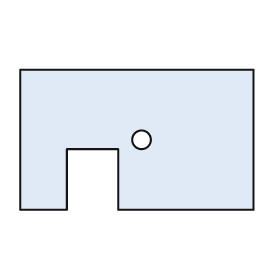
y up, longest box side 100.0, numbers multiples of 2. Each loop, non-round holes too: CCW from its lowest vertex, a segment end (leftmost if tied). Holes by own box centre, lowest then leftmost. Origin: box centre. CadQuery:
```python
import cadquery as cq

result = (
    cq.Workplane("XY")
    .moveTo(-50.0, -30.0)
    .lineTo(-30.0, -30.0)
    .lineTo(-30.0, -4.0)
    .lineTo(-8.0, -4.0)
    .lineTo(-8.0, -30.0)
    .lineTo(50.0, -30.0)
    .lineTo(50.0, 30.0)
    .lineTo(-50.0, 30.0)
    .close()
    .moveTo(2.0, 0.0)
    .circle(4.0)
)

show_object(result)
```